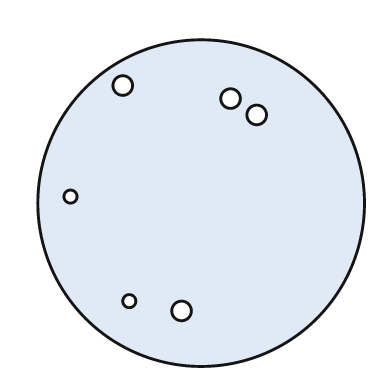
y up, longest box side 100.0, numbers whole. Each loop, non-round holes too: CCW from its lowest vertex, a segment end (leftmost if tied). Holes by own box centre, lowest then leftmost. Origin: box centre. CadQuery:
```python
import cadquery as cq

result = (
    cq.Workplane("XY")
    .moveTo(0.0, 0.0)
    .circle(50.0)
    .moveTo(-6.0, -33.0)
    .circle(3.0)
    .moveTo(-22.0, -30.0)
    .circle(2.0)
    .moveTo(-40.0, 2.0)
    .circle(2.0)
    .moveTo(17.0, 27.0)
    .circle(3.0)
    .moveTo(9.0, 32.0)
    .circle(3.0)
    .moveTo(-24.0, 36.0)
    .circle(3.0)
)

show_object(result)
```